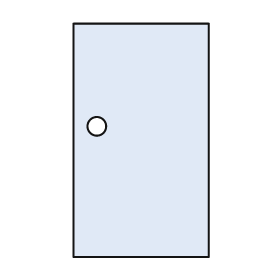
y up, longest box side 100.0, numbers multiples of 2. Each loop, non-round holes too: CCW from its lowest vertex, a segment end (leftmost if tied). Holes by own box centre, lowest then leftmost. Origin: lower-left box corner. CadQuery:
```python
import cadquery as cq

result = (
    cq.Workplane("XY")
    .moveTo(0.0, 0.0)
    .lineTo(58.0, 0.0)
    .lineTo(58.0, 100.0)
    .lineTo(0.0, 100.0)
    .close()
    .moveTo(10.0, 56.0)
    .circle(4.0)
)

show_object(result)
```